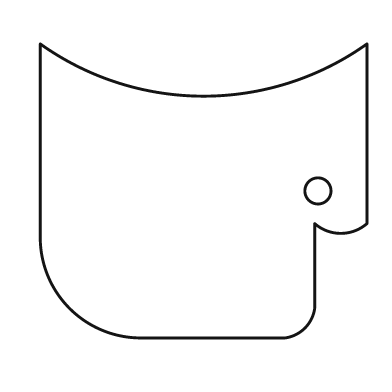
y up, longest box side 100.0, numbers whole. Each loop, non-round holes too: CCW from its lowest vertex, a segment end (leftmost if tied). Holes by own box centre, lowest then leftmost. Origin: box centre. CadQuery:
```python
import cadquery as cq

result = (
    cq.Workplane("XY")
    .moveTo(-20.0, -45.0)
    .lineTo(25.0, -45.0)
    .threePointArc((31.0, -42.0), (34.0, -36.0))
    .lineTo(34.0, -10.0)
    .threePointArc((42.0, -13.0), (50.0, -10.0))
    .lineTo(50.0, 45.0)
    .threePointArc((0.0, 29.0), (-50.0, 45.0))
    .lineTo(-50.0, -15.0)
    .threePointArc((-41.0, -36.0), (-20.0, -45.0))
    .close()
    .moveTo(35.0, 0.0)
    .circle(4.0)
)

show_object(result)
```